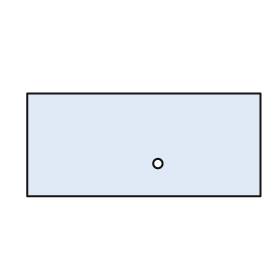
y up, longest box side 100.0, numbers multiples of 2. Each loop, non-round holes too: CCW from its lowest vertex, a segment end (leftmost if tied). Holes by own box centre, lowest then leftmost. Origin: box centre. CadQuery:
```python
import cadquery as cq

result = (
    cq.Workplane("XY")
    .moveTo(-50.0, -22.0)
    .lineTo(50.0, -22.0)
    .lineTo(50.0, 22.0)
    .lineTo(-50.0, 22.0)
    .close()
    .moveTo(6.0, -8.0)
    .circle(2.0)
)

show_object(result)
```